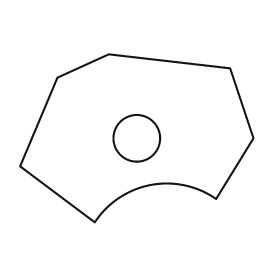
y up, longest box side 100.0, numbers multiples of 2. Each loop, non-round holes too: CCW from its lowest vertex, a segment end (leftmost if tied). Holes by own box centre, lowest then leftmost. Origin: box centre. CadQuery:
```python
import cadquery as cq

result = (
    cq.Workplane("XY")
    .moveTo(-18.0, -36.0)
    .threePointArc((6.0, -20.0), (34.0, -26.0))
    .lineTo(50.0, 0.0)
    .lineTo(40.0, 30.0)
    .lineTo(-12.0, 36.0)
    .lineTo(-34.0, 26.0)
    .lineTo(-50.0, -12.0)
    .close()
    .moveTo(0.0, 0.0)
    .circle(10.0)
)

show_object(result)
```